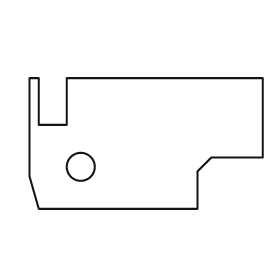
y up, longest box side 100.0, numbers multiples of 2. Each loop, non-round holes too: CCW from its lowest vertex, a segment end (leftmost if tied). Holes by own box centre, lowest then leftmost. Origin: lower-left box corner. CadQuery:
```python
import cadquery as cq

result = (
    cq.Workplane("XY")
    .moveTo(4.0, 0.0)
    .lineTo(72.0, 0.0)
    .lineTo(72.0, 16.0)
    .lineTo(78.0, 22.0)
    .lineTo(100.0, 22.0)
    .lineTo(100.0, 56.0)
    .lineTo(16.0, 56.0)
    .lineTo(16.0, 36.0)
    .lineTo(4.0, 36.0)
    .lineTo(4.0, 56.0)
    .lineTo(0.0, 56.0)
    .lineTo(0.0, 14.0)
    .close()
    .moveTo(22.0, 18.0)
    .circle(6.0)
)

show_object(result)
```